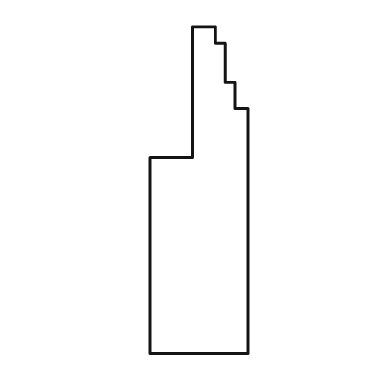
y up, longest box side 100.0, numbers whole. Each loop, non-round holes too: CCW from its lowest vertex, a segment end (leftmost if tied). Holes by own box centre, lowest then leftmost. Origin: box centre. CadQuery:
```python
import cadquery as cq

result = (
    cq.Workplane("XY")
    .moveTo(-15.0, -50.0)
    .lineTo(15.0, -50.0)
    .lineTo(15.0, 25.0)
    .lineTo(11.0, 25.0)
    .lineTo(11.0, 33.0)
    .lineTo(8.0, 33.0)
    .lineTo(8.0, 45.0)
    .lineTo(5.0, 45.0)
    .lineTo(5.0, 50.0)
    .lineTo(-2.0, 50.0)
    .lineTo(-2.0, 10.0)
    .lineTo(-15.0, 10.0)
    .close()
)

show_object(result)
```